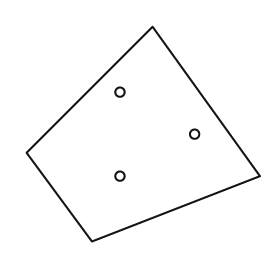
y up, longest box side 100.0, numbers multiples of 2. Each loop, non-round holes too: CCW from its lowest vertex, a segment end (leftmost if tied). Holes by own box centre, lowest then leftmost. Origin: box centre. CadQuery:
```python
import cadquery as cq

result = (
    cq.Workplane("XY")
    .moveTo(-22.0, -46.0)
    .lineTo(50.0, -18.0)
    .lineTo(4.0, 46.0)
    .lineTo(-50.0, -8.0)
    .close()
    .moveTo(-10.0, -18.0)
    .circle(2.0)
    .moveTo(22.0, 0.0)
    .circle(2.0)
    .moveTo(-10.0, 18.0)
    .circle(2.0)
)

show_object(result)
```